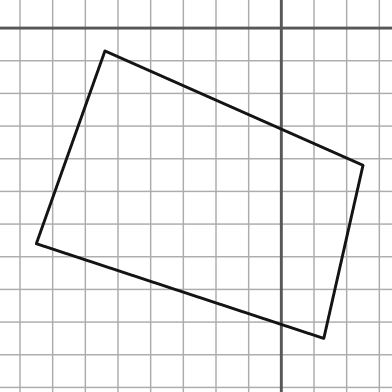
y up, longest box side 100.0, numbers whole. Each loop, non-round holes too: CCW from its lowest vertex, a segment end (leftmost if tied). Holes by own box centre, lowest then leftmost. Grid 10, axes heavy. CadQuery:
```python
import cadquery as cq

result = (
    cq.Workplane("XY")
    .moveTo(13.0, -95.0)
    .lineTo(25.0, -42.0)
    .lineTo(-54.0, -7.0)
    .lineTo(-75.0, -66.0)
    .close()
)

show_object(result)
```